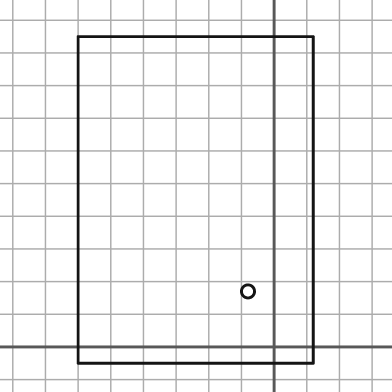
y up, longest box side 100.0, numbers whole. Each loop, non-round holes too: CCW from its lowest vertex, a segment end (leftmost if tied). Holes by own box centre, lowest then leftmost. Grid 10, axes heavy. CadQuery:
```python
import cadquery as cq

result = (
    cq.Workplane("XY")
    .moveTo(-60.0, -5.0)
    .lineTo(12.0, -5.0)
    .lineTo(12.0, 95.0)
    .lineTo(-60.0, 95.0)
    .close()
    .moveTo(-8.0, 17.0)
    .circle(2.0)
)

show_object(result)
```